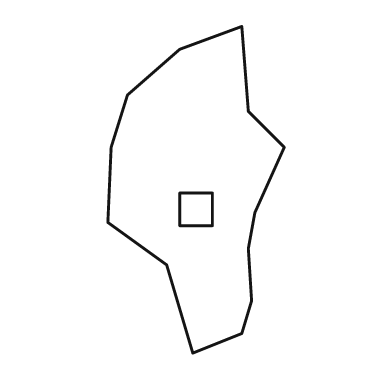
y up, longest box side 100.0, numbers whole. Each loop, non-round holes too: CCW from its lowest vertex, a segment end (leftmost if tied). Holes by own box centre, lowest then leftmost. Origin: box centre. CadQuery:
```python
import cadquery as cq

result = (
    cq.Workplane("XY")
    .moveTo(-1.0, -50.0)
    .lineTo(14.0, -44.0)
    .lineTo(17.0, -34.0)
    .lineTo(16.0, -18.0)
    .lineTo(18.0, -7.0)
    .lineTo(27.0, 13.0)
    .lineTo(16.0, 24.0)
    .lineTo(14.0, 50.0)
    .lineTo(-5.0, 43.0)
    .lineTo(-21.0, 29.0)
    .lineTo(-26.0, 13.0)
    .lineTo(-27.0, -10.0)
    .lineTo(-9.0, -23.0)
    .close()
    .moveTo(-5.0, -11.0)
    .lineTo(5.0, -11.0)
    .lineTo(5.0, -1.0)
    .lineTo(-5.0, -1.0)
    .close()
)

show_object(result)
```